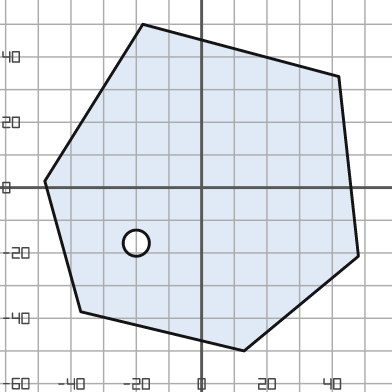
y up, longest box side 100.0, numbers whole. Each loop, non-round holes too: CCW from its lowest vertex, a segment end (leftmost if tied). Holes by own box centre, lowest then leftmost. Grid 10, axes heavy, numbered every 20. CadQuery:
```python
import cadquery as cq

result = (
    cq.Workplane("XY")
    .moveTo(13.0, -50.0)
    .lineTo(48.0, -21.0)
    .lineTo(42.0, 34.0)
    .lineTo(-18.0, 50.0)
    .lineTo(-48.0, 2.0)
    .lineTo(-37.0, -38.0)
    .close()
    .moveTo(-20.0, -17.0)
    .circle(4.0)
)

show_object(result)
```